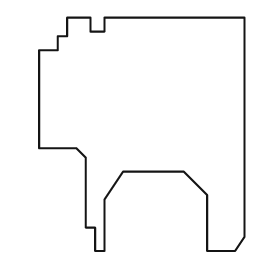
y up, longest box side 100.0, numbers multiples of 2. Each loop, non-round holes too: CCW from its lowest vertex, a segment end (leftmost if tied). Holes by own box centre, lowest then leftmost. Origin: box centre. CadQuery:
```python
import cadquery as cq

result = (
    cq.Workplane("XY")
    .moveTo(-20.0, -50.0)
    .lineTo(-16.0, -50.0)
    .lineTo(-16.0, -28.0)
    .lineTo(-8.0, -16.0)
    .lineTo(18.0, -16.0)
    .lineTo(28.0, -26.0)
    .lineTo(28.0, -50.0)
    .lineTo(40.0, -50.0)
    .lineTo(44.0, -44.0)
    .lineTo(44.0, 50.0)
    .lineTo(-16.0, 50.0)
    .lineTo(-16.0, 44.0)
    .lineTo(-22.0, 44.0)
    .lineTo(-22.0, 50.0)
    .lineTo(-32.0, 50.0)
    .lineTo(-32.0, 42.0)
    .lineTo(-36.0, 42.0)
    .lineTo(-36.0, 36.0)
    .lineTo(-44.0, 36.0)
    .lineTo(-44.0, -6.0)
    .lineTo(-28.0, -6.0)
    .lineTo(-24.0, -10.0)
    .lineTo(-24.0, -40.0)
    .lineTo(-20.0, -40.0)
    .close()
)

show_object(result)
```